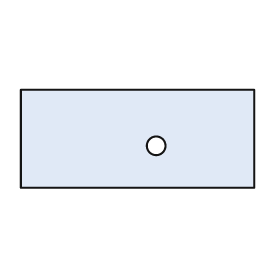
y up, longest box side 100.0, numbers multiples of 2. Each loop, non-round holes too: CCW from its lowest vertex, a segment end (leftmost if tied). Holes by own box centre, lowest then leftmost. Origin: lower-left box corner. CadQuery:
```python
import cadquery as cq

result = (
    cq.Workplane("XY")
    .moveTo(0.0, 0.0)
    .lineTo(100.0, 0.0)
    .lineTo(100.0, 42.0)
    .lineTo(0.0, 42.0)
    .close()
    .moveTo(58.0, 18.0)
    .circle(4.0)
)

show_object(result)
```